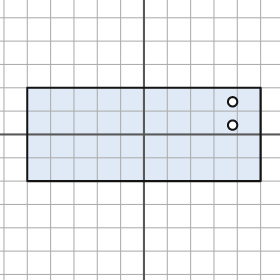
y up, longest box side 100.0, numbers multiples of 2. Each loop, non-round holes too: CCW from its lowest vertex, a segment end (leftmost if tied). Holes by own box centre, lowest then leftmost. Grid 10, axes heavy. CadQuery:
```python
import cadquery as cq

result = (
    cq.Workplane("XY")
    .moveTo(-50.0, -20.0)
    .lineTo(50.0, -20.0)
    .lineTo(50.0, 20.0)
    .lineTo(-50.0, 20.0)
    .close()
    .moveTo(38.0, 4.0)
    .circle(2.0)
    .moveTo(38.0, 14.0)
    .circle(2.0)
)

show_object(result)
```